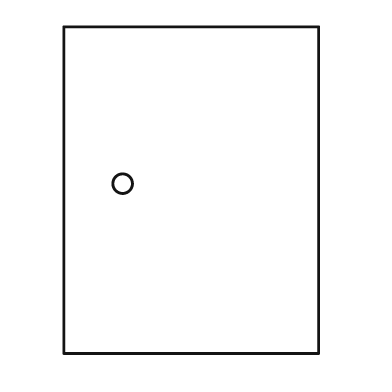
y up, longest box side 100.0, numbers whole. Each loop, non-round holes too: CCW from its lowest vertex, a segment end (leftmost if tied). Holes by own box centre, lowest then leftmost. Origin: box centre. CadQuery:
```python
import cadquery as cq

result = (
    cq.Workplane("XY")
    .moveTo(-39.0, -50.0)
    .lineTo(39.0, -50.0)
    .lineTo(39.0, 50.0)
    .lineTo(-39.0, 50.0)
    .close()
    .moveTo(-21.0, 2.0)
    .circle(3.0)
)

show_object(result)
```